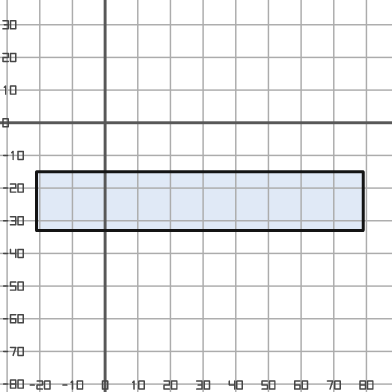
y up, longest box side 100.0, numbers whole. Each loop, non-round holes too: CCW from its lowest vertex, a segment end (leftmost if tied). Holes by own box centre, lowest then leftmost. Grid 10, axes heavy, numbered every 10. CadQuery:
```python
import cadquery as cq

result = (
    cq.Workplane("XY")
    .moveTo(-21.0, -33.0)
    .lineTo(79.0, -33.0)
    .lineTo(79.0, -15.0)
    .lineTo(-21.0, -15.0)
    .close()
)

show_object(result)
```